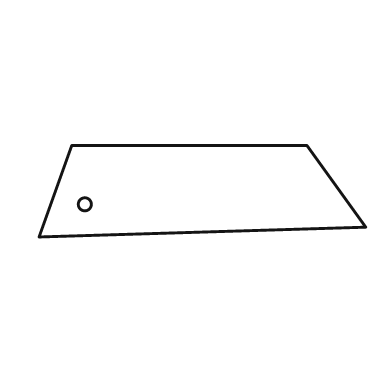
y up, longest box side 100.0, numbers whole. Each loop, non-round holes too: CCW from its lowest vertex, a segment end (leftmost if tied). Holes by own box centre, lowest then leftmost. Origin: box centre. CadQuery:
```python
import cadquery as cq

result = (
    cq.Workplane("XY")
    .moveTo(-50.0, -14.0)
    .lineTo(50.0, -11.0)
    .lineTo(32.0, 14.0)
    .lineTo(-40.0, 14.0)
    .close()
    .moveTo(-36.0, -4.0)
    .circle(2.0)
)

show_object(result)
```